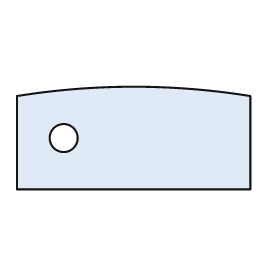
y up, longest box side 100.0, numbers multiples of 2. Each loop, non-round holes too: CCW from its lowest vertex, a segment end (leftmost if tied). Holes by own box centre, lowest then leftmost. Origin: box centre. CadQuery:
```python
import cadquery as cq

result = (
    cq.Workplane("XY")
    .moveTo(-50.0, -22.0)
    .lineTo(50.0, -22.0)
    .lineTo(50.0, 18.0)
    .threePointArc((0.0, 22.0), (-50.0, 18.0))
    .close()
    .moveTo(-30.0, 0.0)
    .circle(6.0)
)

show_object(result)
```